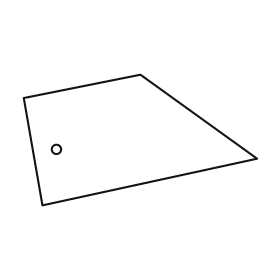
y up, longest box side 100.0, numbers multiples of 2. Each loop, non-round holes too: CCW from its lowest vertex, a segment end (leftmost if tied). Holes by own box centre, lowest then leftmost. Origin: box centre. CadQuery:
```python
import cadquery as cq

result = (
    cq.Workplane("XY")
    .moveTo(-42.0, -28.0)
    .lineTo(50.0, -8.0)
    .lineTo(0.0, 28.0)
    .lineTo(-50.0, 18.0)
    .close()
    .moveTo(-36.0, -4.0)
    .circle(2.0)
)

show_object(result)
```